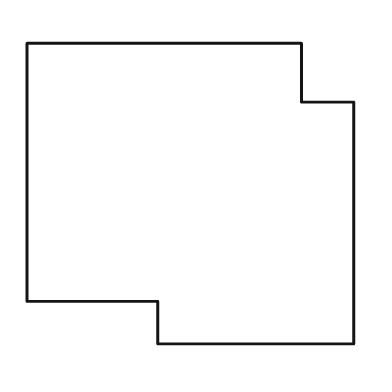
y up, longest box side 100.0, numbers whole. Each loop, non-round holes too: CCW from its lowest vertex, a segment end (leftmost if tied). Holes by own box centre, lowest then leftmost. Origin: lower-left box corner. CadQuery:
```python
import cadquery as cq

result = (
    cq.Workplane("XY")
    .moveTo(40.0, 0.0)
    .lineTo(100.0, 0.0)
    .lineTo(100.0, 74.0)
    .lineTo(84.0, 74.0)
    .lineTo(84.0, 92.0)
    .lineTo(0.0, 92.0)
    .lineTo(0.0, 13.0)
    .lineTo(40.0, 13.0)
    .close()
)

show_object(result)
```